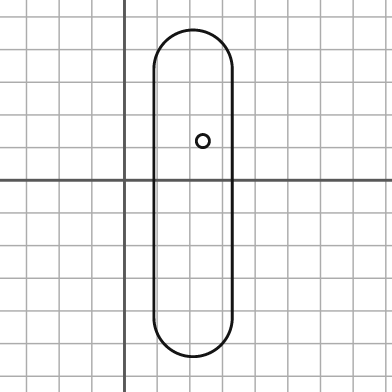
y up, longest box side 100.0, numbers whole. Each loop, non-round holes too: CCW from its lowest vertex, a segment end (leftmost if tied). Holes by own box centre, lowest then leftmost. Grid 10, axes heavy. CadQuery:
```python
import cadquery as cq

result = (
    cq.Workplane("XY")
    .moveTo(9.0, -42.0)
    .threePointArc((21.0, -54.0), (33.0, -42.0))
    .lineTo(33.0, 34.0)
    .threePointArc((21.0, 46.0), (9.0, 34.0))
    .close()
    .moveTo(24.0, 12.0)
    .circle(2.0)
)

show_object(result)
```